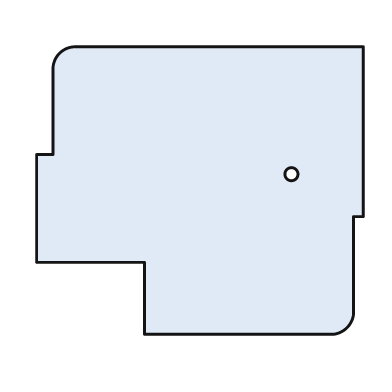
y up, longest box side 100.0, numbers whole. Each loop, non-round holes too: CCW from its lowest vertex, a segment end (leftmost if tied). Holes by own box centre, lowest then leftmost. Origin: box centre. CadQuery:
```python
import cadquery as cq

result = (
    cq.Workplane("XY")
    .moveTo(-17.0, -44.0)
    .lineTo(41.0, -44.0)
    .threePointArc((45.0, -42.0), (47.0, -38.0))
    .lineTo(47.0, -8.0)
    .lineTo(50.0, -8.0)
    .lineTo(50.0, 44.0)
    .lineTo(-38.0, 44.0)
    .threePointArc((-43.0, 42.0), (-45.0, 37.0))
    .lineTo(-45.0, 11.0)
    .lineTo(-50.0, 11.0)
    .lineTo(-50.0, -22.0)
    .lineTo(-17.0, -22.0)
    .close()
    .moveTo(28.0, 5.0)
    .circle(2.0)
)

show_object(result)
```